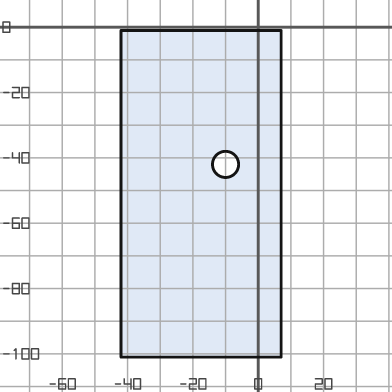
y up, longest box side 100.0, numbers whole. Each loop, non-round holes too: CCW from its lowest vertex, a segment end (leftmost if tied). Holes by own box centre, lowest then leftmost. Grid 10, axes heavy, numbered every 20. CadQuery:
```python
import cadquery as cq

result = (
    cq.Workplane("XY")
    .moveTo(-42.0, -101.0)
    .lineTo(7.0, -101.0)
    .lineTo(7.0, -1.0)
    .lineTo(-42.0, -1.0)
    .close()
    .moveTo(-10.0, -42.0)
    .circle(4.0)
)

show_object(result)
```